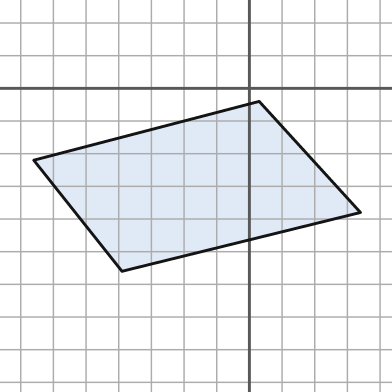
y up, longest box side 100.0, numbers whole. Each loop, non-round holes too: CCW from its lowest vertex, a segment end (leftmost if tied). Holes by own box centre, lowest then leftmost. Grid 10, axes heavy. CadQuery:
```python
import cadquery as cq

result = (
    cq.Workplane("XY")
    .moveTo(-39.0, -56.0)
    .lineTo(34.0, -38.0)
    .lineTo(3.0, -4.0)
    .lineTo(-66.0, -22.0)
    .close()
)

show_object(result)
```